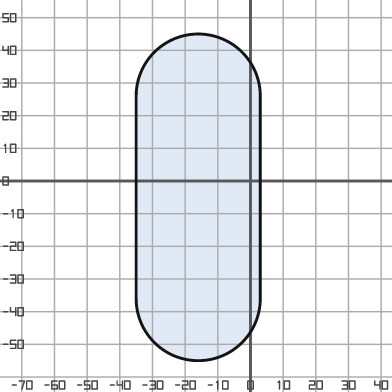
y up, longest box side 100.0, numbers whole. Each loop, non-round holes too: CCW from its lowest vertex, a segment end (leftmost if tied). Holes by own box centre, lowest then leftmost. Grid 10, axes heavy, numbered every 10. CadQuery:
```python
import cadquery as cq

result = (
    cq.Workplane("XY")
    .moveTo(-35.0, -36.0)
    .threePointArc((-16.0, -55.0), (3.0, -36.0))
    .lineTo(3.0, 26.0)
    .threePointArc((-16.0, 45.0), (-35.0, 26.0))
    .close()
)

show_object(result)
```